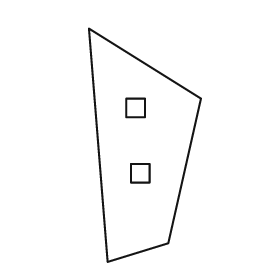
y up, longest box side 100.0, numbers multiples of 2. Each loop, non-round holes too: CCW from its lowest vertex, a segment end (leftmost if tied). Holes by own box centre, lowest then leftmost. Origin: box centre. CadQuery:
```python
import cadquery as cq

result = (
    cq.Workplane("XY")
    .moveTo(-16.0, -50.0)
    .lineTo(10.0, -42.0)
    .lineTo(24.0, 20.0)
    .lineTo(-24.0, 50.0)
    .close()
    .moveTo(-6.0, -16.0)
    .lineTo(2.0, -16.0)
    .lineTo(2.0, -8.0)
    .lineTo(-6.0, -8.0)
    .close()
    .moveTo(-8.0, 12.0)
    .lineTo(0.0, 12.0)
    .lineTo(0.0, 20.0)
    .lineTo(-8.0, 20.0)
    .close()
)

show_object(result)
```